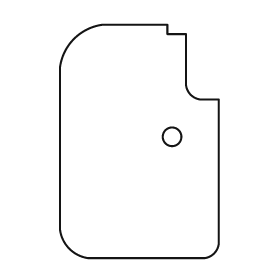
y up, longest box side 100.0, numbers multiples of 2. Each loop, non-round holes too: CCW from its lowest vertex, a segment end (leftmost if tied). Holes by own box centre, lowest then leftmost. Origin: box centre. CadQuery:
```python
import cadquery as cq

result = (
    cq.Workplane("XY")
    .moveTo(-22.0, -50.0)
    .lineTo(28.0, -50.0)
    .threePointArc((32.0, -48.0), (34.0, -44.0))
    .lineTo(34.0, 18.0)
    .lineTo(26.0, 18.0)
    .threePointArc((22.0, 20.0), (20.0, 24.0))
    .lineTo(20.0, 46.0)
    .lineTo(12.0, 46.0)
    .lineTo(12.0, 50.0)
    .lineTo(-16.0, 50.0)
    .threePointArc((-28.0, 44.0), (-34.0, 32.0))
    .lineTo(-34.0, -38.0)
    .threePointArc((-30.0, -46.0), (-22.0, -50.0))
    .close()
    .moveTo(14.0, 2.0)
    .circle(4.0)
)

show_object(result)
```